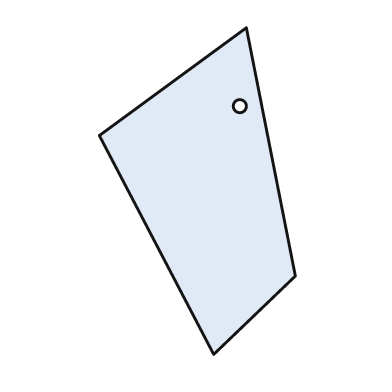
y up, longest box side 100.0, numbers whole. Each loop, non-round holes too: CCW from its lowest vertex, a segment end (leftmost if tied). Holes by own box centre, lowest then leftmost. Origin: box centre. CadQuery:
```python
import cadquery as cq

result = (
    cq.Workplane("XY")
    .moveTo(5.0, -50.0)
    .lineTo(30.0, -26.0)
    .lineTo(15.0, 50.0)
    .lineTo(-30.0, 17.0)
    .close()
    .moveTo(13.0, 26.0)
    .circle(2.0)
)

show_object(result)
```